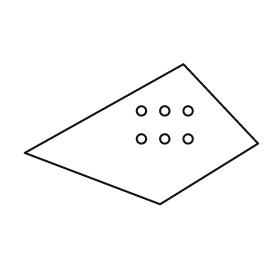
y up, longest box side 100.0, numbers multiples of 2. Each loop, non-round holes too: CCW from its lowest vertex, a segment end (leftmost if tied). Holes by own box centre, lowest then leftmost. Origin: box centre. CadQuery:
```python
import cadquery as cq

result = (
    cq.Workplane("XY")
    .moveTo(8.0, -30.0)
    .lineTo(50.0, -4.0)
    .lineTo(18.0, 30.0)
    .lineTo(-50.0, -8.0)
    .close()
    .moveTo(0.0, -2.0)
    .circle(2.0)
    .moveTo(10.0, -2.0)
    .circle(2.0)
    .moveTo(20.0, -2.0)
    .circle(2.0)
    .moveTo(0.0, 10.0)
    .circle(2.0)
    .moveTo(10.0, 10.0)
    .circle(2.0)
    .moveTo(20.0, 10.0)
    .circle(2.0)
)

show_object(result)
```